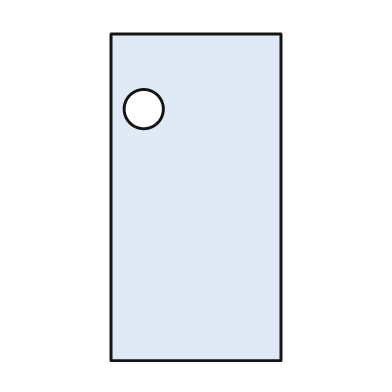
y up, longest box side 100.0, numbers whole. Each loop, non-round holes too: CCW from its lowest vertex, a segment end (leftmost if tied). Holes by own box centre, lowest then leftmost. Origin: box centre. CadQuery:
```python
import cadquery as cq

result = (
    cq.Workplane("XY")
    .moveTo(-26.0, -50.0)
    .lineTo(26.0, -50.0)
    .lineTo(26.0, 50.0)
    .lineTo(-26.0, 50.0)
    .close()
    .moveTo(-16.0, 27.0)
    .circle(6.0)
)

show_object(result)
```